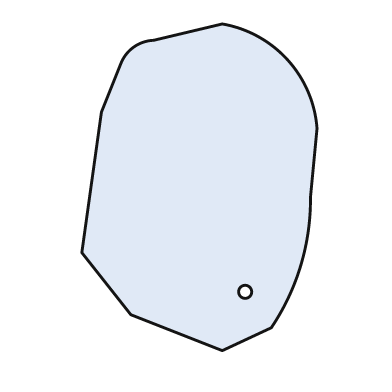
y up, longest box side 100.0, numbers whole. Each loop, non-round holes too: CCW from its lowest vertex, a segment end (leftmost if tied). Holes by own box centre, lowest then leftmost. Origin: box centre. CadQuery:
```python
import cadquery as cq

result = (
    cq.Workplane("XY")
    .moveTo(7.0, -50.0)
    .lineTo(22.0, -43.0)
    .threePointArc((31.0, -24.0), (34.0, -3.0))
    .lineTo(36.0, 18.0)
    .threePointArc((27.0, 39.0), (7.0, 50.0))
    .lineTo(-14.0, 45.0)
    .threePointArc((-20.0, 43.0), (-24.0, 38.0))
    .lineTo(-30.0, 23.0)
    .lineTo(-36.0, -20.0)
    .lineTo(-21.0, -39.0)
    .close()
    .moveTo(14.0, -32.0)
    .circle(2.0)
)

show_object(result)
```